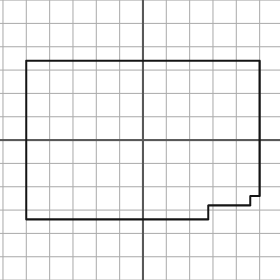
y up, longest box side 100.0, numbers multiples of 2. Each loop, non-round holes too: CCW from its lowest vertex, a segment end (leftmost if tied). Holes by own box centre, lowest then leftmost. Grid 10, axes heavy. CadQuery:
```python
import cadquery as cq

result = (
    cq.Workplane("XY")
    .moveTo(-50.0, -34.0)
    .lineTo(28.0, -34.0)
    .lineTo(28.0, -28.0)
    .lineTo(46.0, -28.0)
    .lineTo(46.0, -24.0)
    .lineTo(50.0, -24.0)
    .lineTo(50.0, 34.0)
    .lineTo(-50.0, 34.0)
    .close()
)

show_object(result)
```